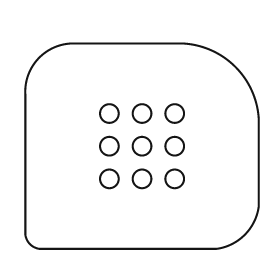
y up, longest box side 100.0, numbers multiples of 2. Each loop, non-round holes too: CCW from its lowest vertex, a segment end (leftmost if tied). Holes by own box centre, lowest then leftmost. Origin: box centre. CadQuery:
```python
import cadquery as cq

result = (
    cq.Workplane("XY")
    .moveTo(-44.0, -44.0)
    .lineTo(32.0, -44.0)
    .threePointArc((44.0, -38.0), (50.0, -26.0))
    .lineTo(50.0, 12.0)
    .threePointArc((40.0, 34.0), (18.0, 44.0))
    .lineTo(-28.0, 44.0)
    .threePointArc((-44.0, 38.0), (-50.0, 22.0))
    .lineTo(-50.0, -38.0)
    .threePointArc((-48.0, -42.0), (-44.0, -44.0))
    .close()
    .moveTo(-14.0, -14.0)
    .circle(4.0)
    .moveTo(0.0, -14.0)
    .circle(4.0)
    .moveTo(14.0, -14.0)
    .circle(4.0)
    .moveTo(-14.0, 0.0)
    .circle(4.0)
    .moveTo(0.0, 0.0)
    .circle(4.0)
    .moveTo(14.0, 0.0)
    .circle(4.0)
    .moveTo(-14.0, 14.0)
    .circle(4.0)
    .moveTo(0.0, 14.0)
    .circle(4.0)
    .moveTo(14.0, 14.0)
    .circle(4.0)
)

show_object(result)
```